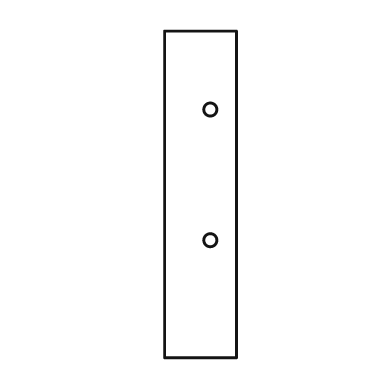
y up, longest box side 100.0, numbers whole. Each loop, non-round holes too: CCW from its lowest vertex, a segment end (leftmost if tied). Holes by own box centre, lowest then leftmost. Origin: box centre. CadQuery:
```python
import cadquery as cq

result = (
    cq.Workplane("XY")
    .moveTo(-11.0, -50.0)
    .lineTo(11.0, -50.0)
    .lineTo(11.0, 50.0)
    .lineTo(-11.0, 50.0)
    .close()
    .moveTo(3.0, -14.0)
    .circle(2.0)
    .moveTo(3.0, 26.0)
    .circle(2.0)
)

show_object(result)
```